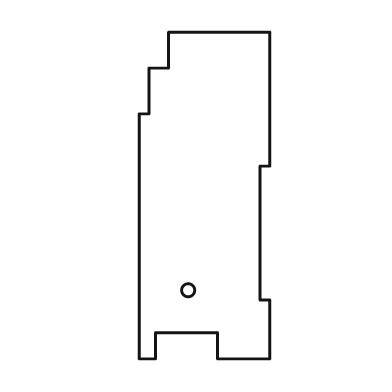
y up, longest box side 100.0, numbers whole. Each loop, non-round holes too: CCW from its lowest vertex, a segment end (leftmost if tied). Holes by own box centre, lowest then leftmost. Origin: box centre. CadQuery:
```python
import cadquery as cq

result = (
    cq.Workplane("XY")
    .moveTo(-20.0, -50.0)
    .lineTo(-15.0, -50.0)
    .lineTo(-15.0, -42.0)
    .lineTo(4.0, -42.0)
    .lineTo(4.0, -50.0)
    .lineTo(20.0, -50.0)
    .lineTo(20.0, -32.0)
    .lineTo(17.0, -32.0)
    .lineTo(17.0, 9.0)
    .lineTo(20.0, 9.0)
    .lineTo(20.0, 50.0)
    .lineTo(-11.0, 50.0)
    .lineTo(-11.0, 39.0)
    .lineTo(-17.0, 39.0)
    .lineTo(-17.0, 25.0)
    .lineTo(-20.0, 25.0)
    .close()
    .moveTo(-5.0, -29.0)
    .circle(2.0)
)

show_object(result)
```